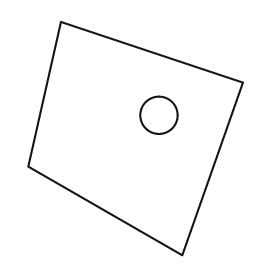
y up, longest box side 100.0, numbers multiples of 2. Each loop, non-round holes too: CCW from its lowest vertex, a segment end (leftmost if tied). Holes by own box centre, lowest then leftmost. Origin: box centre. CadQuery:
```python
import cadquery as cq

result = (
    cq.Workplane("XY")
    .moveTo(20.0, -50.0)
    .lineTo(46.0, 24.0)
    .lineTo(-32.0, 50.0)
    .lineTo(-46.0, -12.0)
    .close()
    .moveTo(10.0, 10.0)
    .circle(8.0)
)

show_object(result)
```